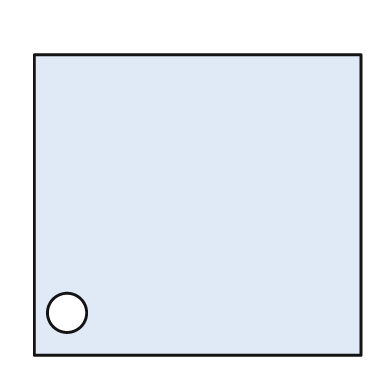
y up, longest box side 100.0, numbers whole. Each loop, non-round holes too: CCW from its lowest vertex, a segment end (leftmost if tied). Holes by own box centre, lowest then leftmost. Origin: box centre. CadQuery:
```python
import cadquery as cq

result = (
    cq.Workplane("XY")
    .moveTo(-50.0, -46.0)
    .lineTo(50.0, -46.0)
    .lineTo(50.0, 46.0)
    .lineTo(-50.0, 46.0)
    .close()
    .moveTo(-40.0, -33.0)
    .circle(6.0)
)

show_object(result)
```